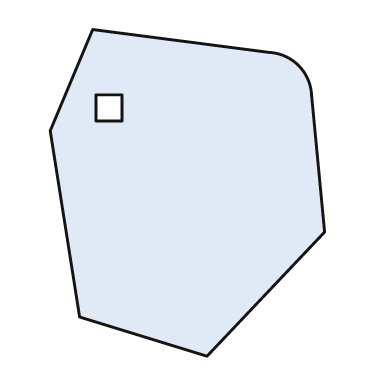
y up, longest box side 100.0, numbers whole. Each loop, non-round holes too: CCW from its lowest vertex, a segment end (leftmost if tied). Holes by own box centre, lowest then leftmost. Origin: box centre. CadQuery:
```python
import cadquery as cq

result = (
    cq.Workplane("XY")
    .moveTo(6.0, -50.0)
    .lineTo(42.0, -12.0)
    .lineTo(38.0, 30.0)
    .threePointArc((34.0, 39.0), (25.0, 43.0))
    .lineTo(-29.0, 50.0)
    .lineTo(-42.0, 19.0)
    .lineTo(-33.0, -38.0)
    .close()
    .moveTo(-28.0, 22.0)
    .lineTo(-20.0, 22.0)
    .lineTo(-20.0, 30.0)
    .lineTo(-28.0, 30.0)
    .close()
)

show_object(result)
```